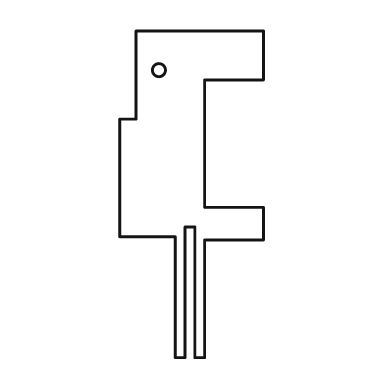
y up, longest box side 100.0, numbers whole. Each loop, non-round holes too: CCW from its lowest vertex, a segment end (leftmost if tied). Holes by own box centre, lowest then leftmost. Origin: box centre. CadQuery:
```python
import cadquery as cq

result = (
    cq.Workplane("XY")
    .moveTo(-5.0, -50.0)
    .lineTo(-2.0, -50.0)
    .lineTo(-2.0, -10.0)
    .lineTo(1.0, -10.0)
    .lineTo(1.0, -50.0)
    .lineTo(4.0, -50.0)
    .lineTo(4.0, -14.0)
    .lineTo(22.0, -14.0)
    .lineTo(22.0, -4.0)
    .lineTo(4.0, -4.0)
    .lineTo(4.0, 35.0)
    .lineTo(22.0, 35.0)
    .lineTo(22.0, 50.0)
    .lineTo(-17.0, 50.0)
    .lineTo(-17.0, 23.0)
    .lineTo(-22.0, 23.0)
    .lineTo(-22.0, -13.0)
    .lineTo(-5.0, -13.0)
    .close()
    .moveTo(-10.0, 38.0)
    .circle(2.0)
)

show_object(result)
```